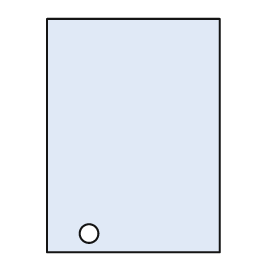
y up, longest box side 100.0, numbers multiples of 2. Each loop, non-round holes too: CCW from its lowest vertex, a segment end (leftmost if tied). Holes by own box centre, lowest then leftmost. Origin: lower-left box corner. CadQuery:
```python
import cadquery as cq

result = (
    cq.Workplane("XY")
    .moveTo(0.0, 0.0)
    .lineTo(74.0, 0.0)
    .lineTo(74.0, 100.0)
    .lineTo(0.0, 100.0)
    .close()
    .moveTo(18.0, 8.0)
    .circle(4.0)
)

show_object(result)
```